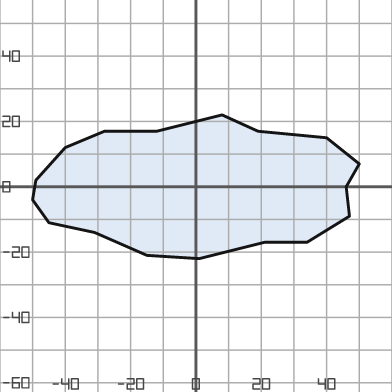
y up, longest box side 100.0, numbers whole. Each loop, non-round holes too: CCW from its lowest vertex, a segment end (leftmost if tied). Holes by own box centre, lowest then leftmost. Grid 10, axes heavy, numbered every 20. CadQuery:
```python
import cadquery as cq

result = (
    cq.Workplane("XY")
    .moveTo(1.0, -22.0)
    .lineTo(21.0, -17.0)
    .lineTo(34.0, -17.0)
    .lineTo(47.0, -9.0)
    .lineTo(46.0, 0.0)
    .lineTo(50.0, 7.0)
    .lineTo(40.0, 15.0)
    .lineTo(19.0, 17.0)
    .lineTo(8.0, 22.0)
    .lineTo(-12.0, 17.0)
    .lineTo(-28.0, 17.0)
    .lineTo(-40.0, 12.0)
    .lineTo(-49.0, 2.0)
    .lineTo(-50.0, -4.0)
    .lineTo(-45.0, -11.0)
    .lineTo(-31.0, -14.0)
    .lineTo(-15.0, -21.0)
    .close()
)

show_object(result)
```